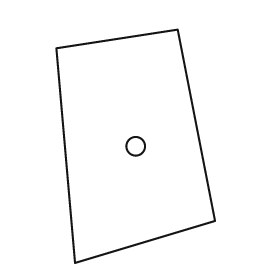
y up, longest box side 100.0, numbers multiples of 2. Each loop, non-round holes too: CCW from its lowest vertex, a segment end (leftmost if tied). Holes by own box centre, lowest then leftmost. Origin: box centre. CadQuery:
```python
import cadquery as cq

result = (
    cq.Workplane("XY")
    .moveTo(-26.0, -50.0)
    .lineTo(34.0, -32.0)
    .lineTo(18.0, 50.0)
    .lineTo(-34.0, 42.0)
    .close()
    .moveTo(0.0, 0.0)
    .circle(4.0)
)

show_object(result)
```